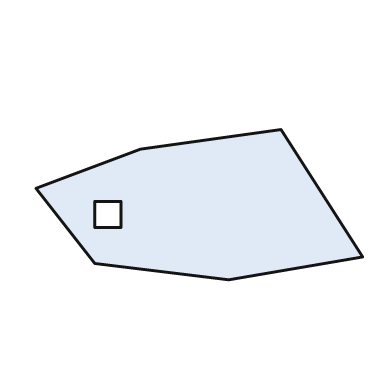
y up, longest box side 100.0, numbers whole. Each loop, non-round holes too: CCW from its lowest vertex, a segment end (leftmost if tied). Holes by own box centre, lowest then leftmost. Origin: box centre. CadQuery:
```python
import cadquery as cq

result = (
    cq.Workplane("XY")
    .moveTo(9.0, -23.0)
    .lineTo(50.0, -16.0)
    .lineTo(25.0, 23.0)
    .lineTo(-18.0, 17.0)
    .lineTo(-50.0, 5.0)
    .lineTo(-32.0, -18.0)
    .close()
    .moveTo(-32.0, -7.0)
    .lineTo(-24.0, -7.0)
    .lineTo(-24.0, 1.0)
    .lineTo(-32.0, 1.0)
    .close()
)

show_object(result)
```